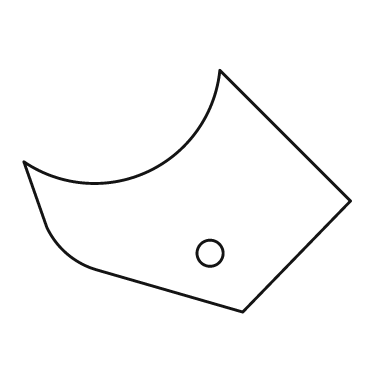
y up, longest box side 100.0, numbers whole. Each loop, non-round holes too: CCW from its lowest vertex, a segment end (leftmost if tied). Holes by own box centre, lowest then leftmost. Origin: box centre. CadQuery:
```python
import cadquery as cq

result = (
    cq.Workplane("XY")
    .moveTo(17.0, -37.0)
    .lineTo(50.0, -3.0)
    .lineTo(10.0, 37.0)
    .threePointArc((-12.0, 6.0), (-50.0, 9.0))
    .lineTo(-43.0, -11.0)
    .threePointArc((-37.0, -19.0), (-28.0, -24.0))
    .close()
    .moveTo(7.0, -19.0)
    .circle(4.0)
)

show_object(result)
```